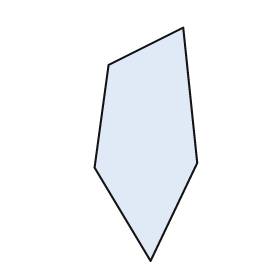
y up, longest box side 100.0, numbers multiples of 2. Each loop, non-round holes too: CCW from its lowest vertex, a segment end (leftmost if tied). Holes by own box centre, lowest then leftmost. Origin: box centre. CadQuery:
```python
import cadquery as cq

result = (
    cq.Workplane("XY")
    .moveTo(2.0, -50.0)
    .lineTo(22.0, -8.0)
    .lineTo(16.0, 50.0)
    .lineTo(-16.0, 34.0)
    .lineTo(-22.0, -10.0)
    .close()
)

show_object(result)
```